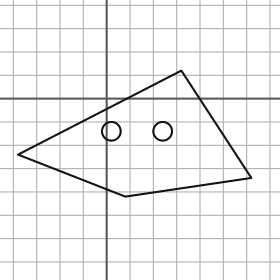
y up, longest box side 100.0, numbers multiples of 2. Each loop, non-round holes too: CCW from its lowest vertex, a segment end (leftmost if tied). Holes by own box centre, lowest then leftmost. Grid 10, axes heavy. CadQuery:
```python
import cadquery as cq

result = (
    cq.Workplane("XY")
    .moveTo(8.0, -42.0)
    .lineTo(62.0, -34.0)
    .lineTo(32.0, 12.0)
    .lineTo(-38.0, -24.0)
    .close()
    .moveTo(2.0, -14.0)
    .circle(4.0)
    .moveTo(24.0, -14.0)
    .circle(4.0)
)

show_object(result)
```